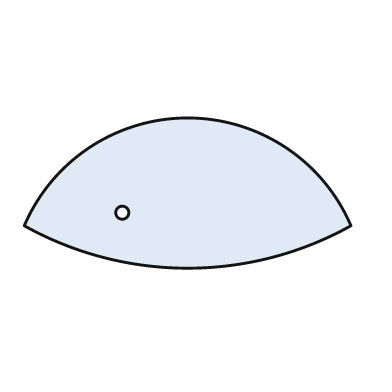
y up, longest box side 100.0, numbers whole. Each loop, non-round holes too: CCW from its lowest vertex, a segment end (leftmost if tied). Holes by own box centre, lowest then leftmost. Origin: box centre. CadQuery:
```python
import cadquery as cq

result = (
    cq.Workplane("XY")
    .moveTo(-50.0, -10.0)
    .threePointArc((0.0, -23.0), (50.0, -10.0))
    .threePointArc((0.0, 23.0), (-50.0, -10.0))
    .close()
    .moveTo(-20.0, -6.0)
    .circle(2.0)
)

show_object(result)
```